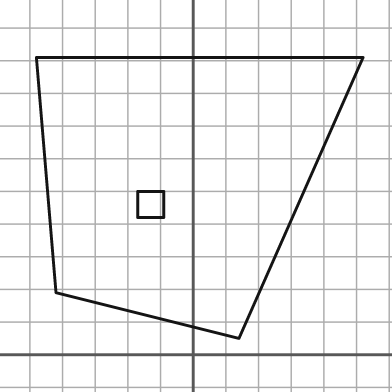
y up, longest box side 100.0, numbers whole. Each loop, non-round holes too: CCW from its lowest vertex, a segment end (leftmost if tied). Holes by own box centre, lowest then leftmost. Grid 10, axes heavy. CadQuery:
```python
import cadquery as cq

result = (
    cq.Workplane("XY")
    .moveTo(14.0, 5.0)
    .lineTo(52.0, 91.0)
    .lineTo(-48.0, 91.0)
    .lineTo(-42.0, 19.0)
    .close()
    .moveTo(-17.0, 42.0)
    .lineTo(-9.0, 42.0)
    .lineTo(-9.0, 50.0)
    .lineTo(-17.0, 50.0)
    .close()
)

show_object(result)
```